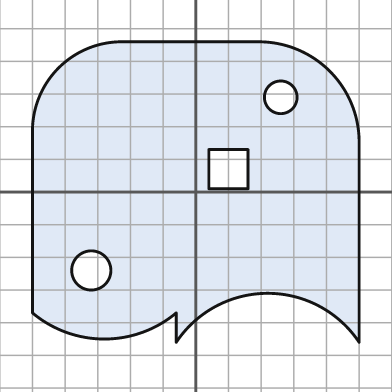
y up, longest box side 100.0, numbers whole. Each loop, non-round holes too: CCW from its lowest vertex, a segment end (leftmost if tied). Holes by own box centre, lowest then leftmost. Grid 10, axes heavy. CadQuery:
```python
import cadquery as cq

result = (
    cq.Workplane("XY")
    .moveTo(-6.0, -46.0)
    .threePointArc((22.0, -31.0), (50.0, -46.0))
    .lineTo(50.0, 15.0)
    .threePointArc((41.0, 37.0), (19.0, 46.0))
    .lineTo(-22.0, 46.0)
    .threePointArc((-42.0, 38.0), (-50.0, 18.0))
    .lineTo(-50.0, -37.0)
    .threePointArc((-28.0, -45.0), (-6.0, -37.0))
    .close()
    .moveTo(-32.0, -24.0)
    .circle(6.0)
    .moveTo(4.0, 1.0)
    .lineTo(16.0, 1.0)
    .lineTo(16.0, 13.0)
    .lineTo(4.0, 13.0)
    .close()
    .moveTo(26.0, 29.0)
    .circle(5.0)
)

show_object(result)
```